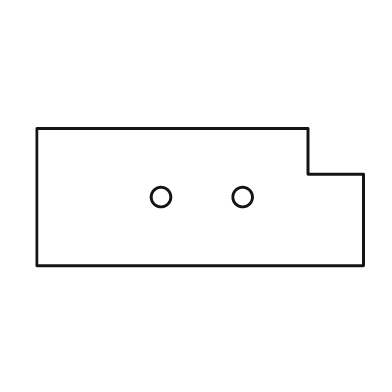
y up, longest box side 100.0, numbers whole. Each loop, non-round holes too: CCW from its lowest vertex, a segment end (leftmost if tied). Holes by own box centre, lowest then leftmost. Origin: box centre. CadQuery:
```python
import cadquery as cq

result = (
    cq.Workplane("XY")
    .moveTo(-50.0, -21.0)
    .lineTo(50.0, -21.0)
    .lineTo(50.0, 7.0)
    .lineTo(33.0, 7.0)
    .lineTo(33.0, 21.0)
    .lineTo(-50.0, 21.0)
    .close()
    .moveTo(-12.0, 0.0)
    .circle(3.0)
    .moveTo(13.0, 0.0)
    .circle(3.0)
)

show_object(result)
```